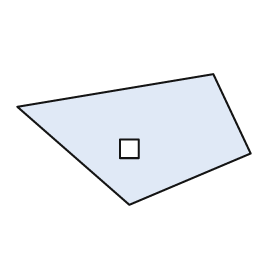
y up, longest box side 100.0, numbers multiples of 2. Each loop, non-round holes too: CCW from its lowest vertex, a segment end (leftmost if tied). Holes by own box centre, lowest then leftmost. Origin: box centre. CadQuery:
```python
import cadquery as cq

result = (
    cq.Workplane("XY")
    .moveTo(-2.0, -28.0)
    .lineTo(50.0, -6.0)
    .lineTo(34.0, 28.0)
    .lineTo(-50.0, 14.0)
    .close()
    .moveTo(-6.0, -8.0)
    .lineTo(2.0, -8.0)
    .lineTo(2.0, 0.0)
    .lineTo(-6.0, 0.0)
    .close()
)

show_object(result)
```